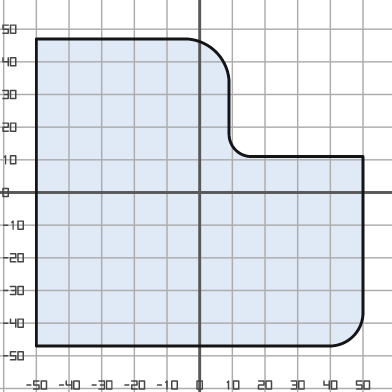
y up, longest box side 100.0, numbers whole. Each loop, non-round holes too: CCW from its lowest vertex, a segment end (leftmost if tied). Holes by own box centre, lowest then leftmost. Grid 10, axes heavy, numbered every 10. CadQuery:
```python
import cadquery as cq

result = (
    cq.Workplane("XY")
    .moveTo(-50.0, -47.0)
    .lineTo(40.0, -47.0)
    .threePointArc((47.0, -44.0), (50.0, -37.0))
    .lineTo(50.0, 11.0)
    .lineTo(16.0, 11.0)
    .threePointArc((11.0, 13.0), (9.0, 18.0))
    .lineTo(9.0, 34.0)
    .threePointArc((5.0, 43.0), (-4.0, 47.0))
    .lineTo(-50.0, 47.0)
    .close()
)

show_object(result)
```